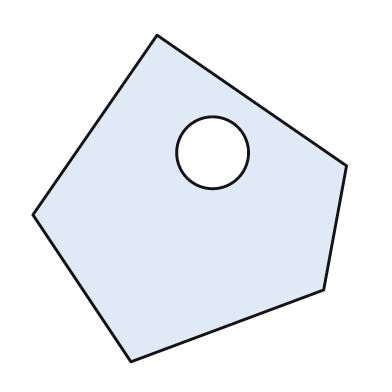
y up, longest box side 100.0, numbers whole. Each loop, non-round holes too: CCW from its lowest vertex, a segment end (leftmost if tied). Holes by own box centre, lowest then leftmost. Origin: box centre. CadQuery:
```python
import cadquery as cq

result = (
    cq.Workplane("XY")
    .moveTo(-18.0, -50.0)
    .lineTo(41.0, -28.0)
    .lineTo(48.0, 10.0)
    .lineTo(-10.0, 50.0)
    .lineTo(-48.0, -5.0)
    .close()
    .moveTo(7.0, 14.0)
    .circle(11.0)
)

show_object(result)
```